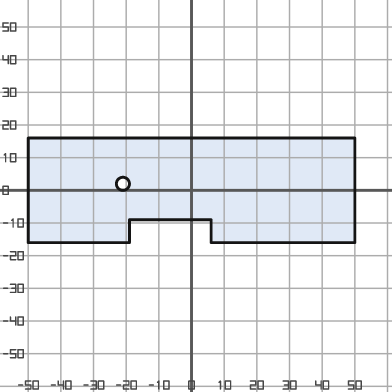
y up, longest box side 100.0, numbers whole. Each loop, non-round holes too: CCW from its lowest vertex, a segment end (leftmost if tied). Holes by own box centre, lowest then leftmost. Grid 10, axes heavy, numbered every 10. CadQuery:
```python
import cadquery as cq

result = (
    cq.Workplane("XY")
    .moveTo(-50.0, -16.0)
    .lineTo(-19.0, -16.0)
    .lineTo(-19.0, -9.0)
    .lineTo(6.0, -9.0)
    .lineTo(6.0, -16.0)
    .lineTo(50.0, -16.0)
    .lineTo(50.0, 16.0)
    .lineTo(-50.0, 16.0)
    .close()
    .moveTo(-21.0, 2.0)
    .circle(2.0)
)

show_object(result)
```